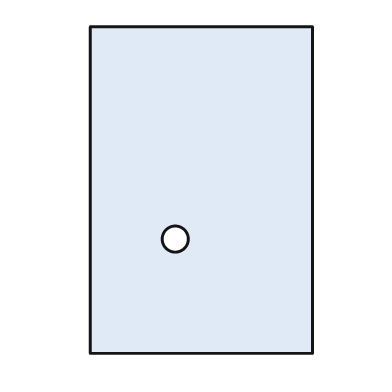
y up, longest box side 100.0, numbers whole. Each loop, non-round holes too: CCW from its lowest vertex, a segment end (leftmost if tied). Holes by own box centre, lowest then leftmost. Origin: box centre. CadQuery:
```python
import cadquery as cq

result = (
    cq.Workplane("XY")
    .moveTo(-34.0, -50.0)
    .lineTo(34.0, -50.0)
    .lineTo(34.0, 50.0)
    .lineTo(-34.0, 50.0)
    .close()
    .moveTo(-8.0, -15.0)
    .circle(4.0)
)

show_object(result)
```